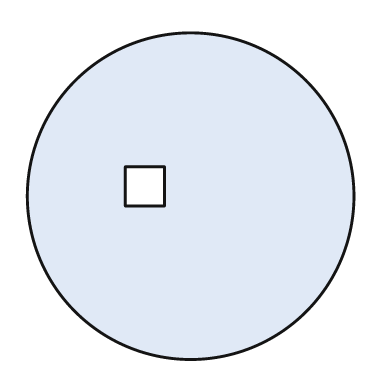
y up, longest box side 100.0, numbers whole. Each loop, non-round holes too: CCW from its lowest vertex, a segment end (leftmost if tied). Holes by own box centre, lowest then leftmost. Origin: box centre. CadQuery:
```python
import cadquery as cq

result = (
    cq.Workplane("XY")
    .moveTo(0.0, 0.0)
    .circle(50.0)
    .moveTo(-20.0, -3.0)
    .lineTo(-8.0, -3.0)
    .lineTo(-8.0, 9.0)
    .lineTo(-20.0, 9.0)
    .close()
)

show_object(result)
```